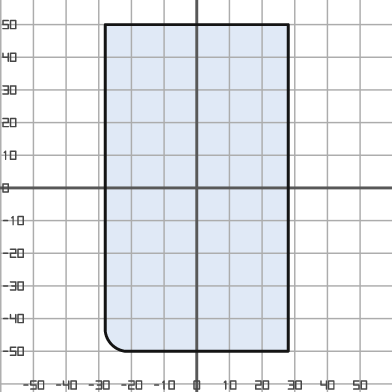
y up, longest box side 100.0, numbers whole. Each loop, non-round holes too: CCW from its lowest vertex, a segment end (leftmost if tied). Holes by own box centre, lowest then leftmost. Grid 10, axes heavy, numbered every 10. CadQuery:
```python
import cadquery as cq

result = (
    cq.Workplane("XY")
    .moveTo(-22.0, -50.0)
    .lineTo(28.0, -50.0)
    .lineTo(28.0, 50.0)
    .lineTo(-28.0, 50.0)
    .lineTo(-28.0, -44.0)
    .threePointArc((-26.0, -48.0), (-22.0, -50.0))
    .close()
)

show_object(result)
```